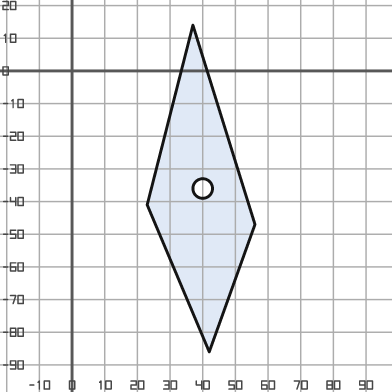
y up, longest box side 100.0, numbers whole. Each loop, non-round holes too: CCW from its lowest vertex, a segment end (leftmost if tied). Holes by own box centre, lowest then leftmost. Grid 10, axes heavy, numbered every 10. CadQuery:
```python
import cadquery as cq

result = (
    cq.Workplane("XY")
    .moveTo(42.0, -86.0)
    .lineTo(56.0, -47.0)
    .lineTo(37.0, 14.0)
    .lineTo(23.0, -41.0)
    .close()
    .moveTo(40.0, -36.0)
    .circle(3.0)
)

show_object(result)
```